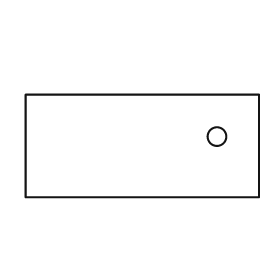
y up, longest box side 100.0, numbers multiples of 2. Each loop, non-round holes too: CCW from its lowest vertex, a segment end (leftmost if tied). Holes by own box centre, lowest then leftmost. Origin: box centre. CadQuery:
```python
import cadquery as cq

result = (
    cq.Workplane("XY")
    .moveTo(-50.0, -22.0)
    .lineTo(50.0, -22.0)
    .lineTo(50.0, 22.0)
    .lineTo(-50.0, 22.0)
    .close()
    .moveTo(32.0, 4.0)
    .circle(4.0)
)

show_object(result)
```